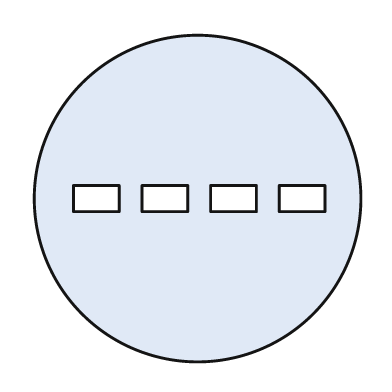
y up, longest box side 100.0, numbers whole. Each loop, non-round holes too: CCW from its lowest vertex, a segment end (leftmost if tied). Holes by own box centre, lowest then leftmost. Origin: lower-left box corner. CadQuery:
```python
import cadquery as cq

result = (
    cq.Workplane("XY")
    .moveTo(50.0, 50.0)
    .circle(50.0)
    .moveTo(12.0, 46.0)
    .lineTo(26.0, 46.0)
    .lineTo(26.0, 54.0)
    .lineTo(12.0, 54.0)
    .close()
    .moveTo(33.0, 46.0)
    .lineTo(47.0, 46.0)
    .lineTo(47.0, 54.0)
    .lineTo(33.0, 54.0)
    .close()
    .moveTo(54.0, 46.0)
    .lineTo(68.0, 46.0)
    .lineTo(68.0, 54.0)
    .lineTo(54.0, 54.0)
    .close()
    .moveTo(75.0, 46.0)
    .lineTo(89.0, 46.0)
    .lineTo(89.0, 54.0)
    .lineTo(75.0, 54.0)
    .close()
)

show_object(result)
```